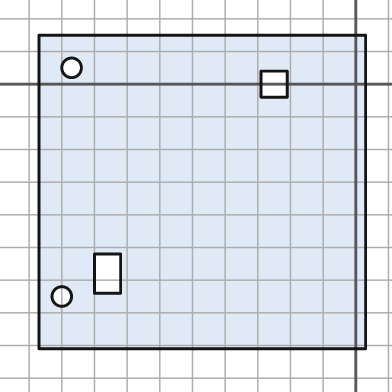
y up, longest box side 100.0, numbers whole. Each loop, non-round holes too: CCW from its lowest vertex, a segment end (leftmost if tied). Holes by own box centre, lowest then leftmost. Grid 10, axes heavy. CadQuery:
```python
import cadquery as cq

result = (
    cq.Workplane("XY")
    .moveTo(-97.0, -81.0)
    .lineTo(3.0, -81.0)
    .lineTo(3.0, 15.0)
    .lineTo(-97.0, 15.0)
    .close()
    .moveTo(-90.0, -65.0)
    .circle(3.0)
    .moveTo(-80.0, -64.0)
    .lineTo(-72.0, -64.0)
    .lineTo(-72.0, -52.0)
    .lineTo(-80.0, -52.0)
    .close()
    .moveTo(-29.0, -4.0)
    .lineTo(-21.0, -4.0)
    .lineTo(-21.0, 4.0)
    .lineTo(-29.0, 4.0)
    .close()
    .moveTo(-87.0, 5.0)
    .circle(3.0)
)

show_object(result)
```